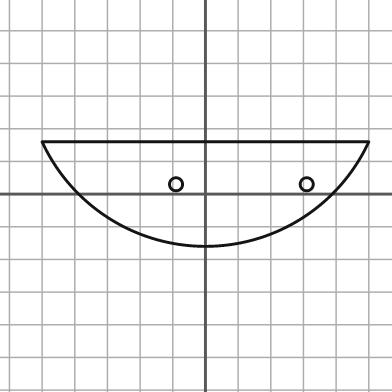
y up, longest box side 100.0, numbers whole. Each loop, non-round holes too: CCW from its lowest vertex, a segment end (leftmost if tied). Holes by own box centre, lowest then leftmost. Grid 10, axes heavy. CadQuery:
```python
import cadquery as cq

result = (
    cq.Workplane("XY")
    .moveTo(-50.0, 16.0)
    .threePointArc((0.0, -16.0), (50.0, 16.0))
    .close()
    .moveTo(-9.0, 3.0)
    .circle(2.0)
    .moveTo(31.0, 3.0)
    .circle(2.0)
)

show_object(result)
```